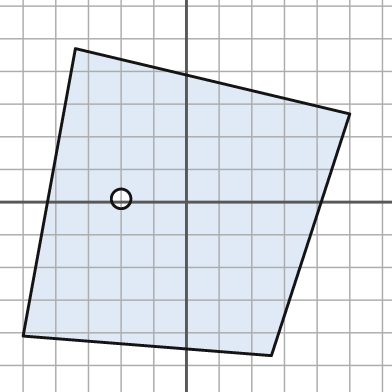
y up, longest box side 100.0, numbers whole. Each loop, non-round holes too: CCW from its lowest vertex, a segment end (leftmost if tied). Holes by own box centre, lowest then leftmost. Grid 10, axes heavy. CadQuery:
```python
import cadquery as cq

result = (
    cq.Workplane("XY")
    .moveTo(26.0, -47.0)
    .lineTo(50.0, 27.0)
    .lineTo(-34.0, 47.0)
    .lineTo(-50.0, -41.0)
    .close()
    .moveTo(-20.0, 1.0)
    .circle(3.0)
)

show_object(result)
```